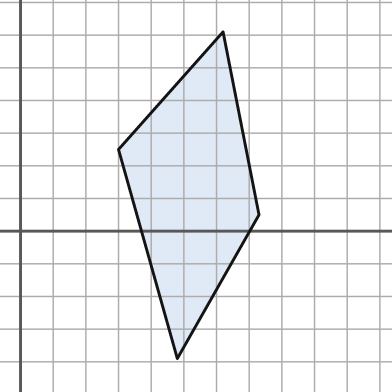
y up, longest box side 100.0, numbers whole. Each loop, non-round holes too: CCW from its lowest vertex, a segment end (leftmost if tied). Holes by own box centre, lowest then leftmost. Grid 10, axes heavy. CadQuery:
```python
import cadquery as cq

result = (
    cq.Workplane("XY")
    .moveTo(48.0, -39.0)
    .lineTo(73.0, 5.0)
    .lineTo(62.0, 61.0)
    .lineTo(30.0, 25.0)
    .close()
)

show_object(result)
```